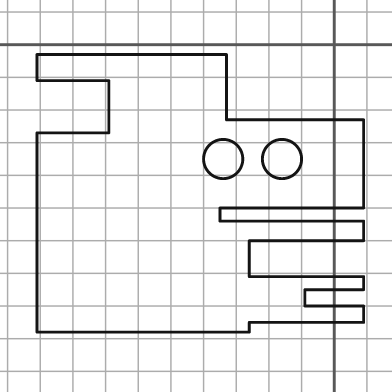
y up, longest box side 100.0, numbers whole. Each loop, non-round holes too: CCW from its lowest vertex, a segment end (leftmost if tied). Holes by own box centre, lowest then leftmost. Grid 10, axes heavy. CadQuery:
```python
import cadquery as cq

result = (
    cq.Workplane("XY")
    .moveTo(-91.0, -88.0)
    .lineTo(-26.0, -88.0)
    .lineTo(-26.0, -85.0)
    .lineTo(9.0, -85.0)
    .lineTo(9.0, -80.0)
    .lineTo(-9.0, -80.0)
    .lineTo(-9.0, -75.0)
    .lineTo(9.0, -75.0)
    .lineTo(9.0, -71.0)
    .lineTo(-26.0, -71.0)
    .lineTo(-26.0, -60.0)
    .lineTo(9.0, -60.0)
    .lineTo(9.0, -54.0)
    .lineTo(-35.0, -54.0)
    .lineTo(-35.0, -50.0)
    .lineTo(9.0, -50.0)
    .lineTo(9.0, -23.0)
    .lineTo(-33.0, -23.0)
    .lineTo(-33.0, -3.0)
    .lineTo(-91.0, -3.0)
    .lineTo(-91.0, -11.0)
    .lineTo(-69.0, -11.0)
    .lineTo(-69.0, -27.0)
    .lineTo(-91.0, -27.0)
    .close()
    .moveTo(-34.0, -35.0)
    .circle(6.0)
    .moveTo(-16.0, -35.0)
    .circle(6.0)
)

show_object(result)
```